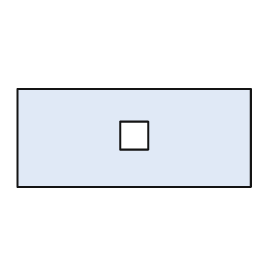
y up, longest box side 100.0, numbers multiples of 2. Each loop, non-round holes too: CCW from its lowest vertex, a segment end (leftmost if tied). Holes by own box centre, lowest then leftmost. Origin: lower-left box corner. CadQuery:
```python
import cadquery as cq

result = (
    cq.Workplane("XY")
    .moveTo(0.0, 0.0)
    .lineTo(100.0, 0.0)
    .lineTo(100.0, 42.0)
    .lineTo(0.0, 42.0)
    .close()
    .moveTo(44.0, 16.0)
    .lineTo(56.0, 16.0)
    .lineTo(56.0, 28.0)
    .lineTo(44.0, 28.0)
    .close()
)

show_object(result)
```